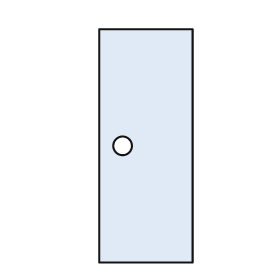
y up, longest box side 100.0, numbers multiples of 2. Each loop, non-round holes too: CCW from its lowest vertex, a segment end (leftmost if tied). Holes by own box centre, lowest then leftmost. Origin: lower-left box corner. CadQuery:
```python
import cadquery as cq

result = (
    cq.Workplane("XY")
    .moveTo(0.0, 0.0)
    .lineTo(40.0, 0.0)
    .lineTo(40.0, 100.0)
    .lineTo(0.0, 100.0)
    .close()
    .moveTo(10.0, 50.0)
    .circle(4.0)
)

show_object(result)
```